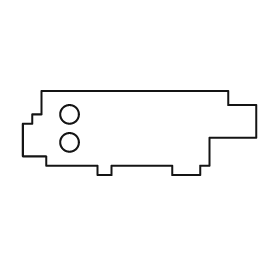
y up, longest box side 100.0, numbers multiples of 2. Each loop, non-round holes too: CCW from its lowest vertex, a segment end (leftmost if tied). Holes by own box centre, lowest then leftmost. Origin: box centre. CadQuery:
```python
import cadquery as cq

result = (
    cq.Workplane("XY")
    .moveTo(-18.0, -18.0)
    .lineTo(-12.0, -18.0)
    .lineTo(-12.0, -14.0)
    .lineTo(14.0, -14.0)
    .lineTo(14.0, -18.0)
    .lineTo(26.0, -18.0)
    .lineTo(26.0, -14.0)
    .lineTo(30.0, -14.0)
    .lineTo(30.0, -2.0)
    .lineTo(50.0, -2.0)
    .lineTo(50.0, 12.0)
    .lineTo(38.0, 12.0)
    .lineTo(38.0, 18.0)
    .lineTo(-42.0, 18.0)
    .lineTo(-42.0, 8.0)
    .lineTo(-46.0, 8.0)
    .lineTo(-46.0, 4.0)
    .lineTo(-50.0, 4.0)
    .lineTo(-50.0, -10.0)
    .lineTo(-40.0, -10.0)
    .lineTo(-40.0, -14.0)
    .lineTo(-18.0, -14.0)
    .close()
    .moveTo(-30.0, -4.0)
    .circle(4.0)
    .moveTo(-30.0, 8.0)
    .circle(4.0)
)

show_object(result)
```